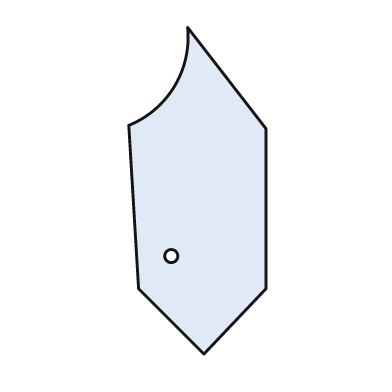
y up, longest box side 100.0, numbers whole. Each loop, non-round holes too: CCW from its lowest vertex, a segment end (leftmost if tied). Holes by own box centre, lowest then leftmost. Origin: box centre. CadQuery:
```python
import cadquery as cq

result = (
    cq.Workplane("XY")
    .moveTo(2.0, -50.0)
    .lineTo(21.0, -30.0)
    .lineTo(21.0, 19.0)
    .lineTo(-3.0, 50.0)
    .threePointArc((-7.0, 32.0), (-21.0, 20.0))
    .lineTo(-18.0, -30.0)
    .close()
    .moveTo(-8.0, -20.0)
    .circle(2.0)
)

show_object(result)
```